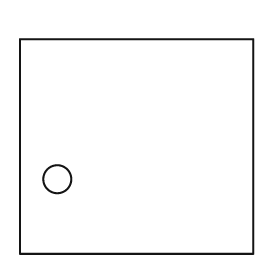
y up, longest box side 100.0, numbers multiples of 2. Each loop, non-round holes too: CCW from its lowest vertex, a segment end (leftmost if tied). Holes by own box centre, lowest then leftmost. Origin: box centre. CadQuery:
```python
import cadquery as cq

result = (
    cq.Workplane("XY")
    .moveTo(-50.0, -46.0)
    .lineTo(50.0, -46.0)
    .lineTo(50.0, 46.0)
    .lineTo(-50.0, 46.0)
    .close()
    .moveTo(-34.0, -14.0)
    .circle(6.0)
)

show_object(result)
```